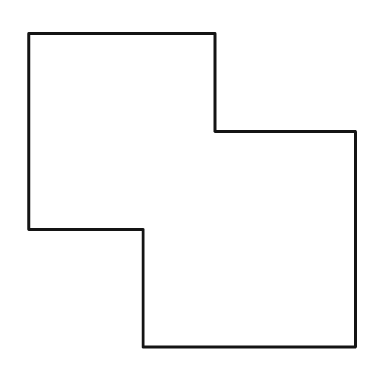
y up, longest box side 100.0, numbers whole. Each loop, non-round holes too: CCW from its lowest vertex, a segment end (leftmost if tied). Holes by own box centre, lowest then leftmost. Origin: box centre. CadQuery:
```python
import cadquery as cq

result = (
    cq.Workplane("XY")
    .moveTo(-15.0, -48.0)
    .lineTo(50.0, -48.0)
    .lineTo(50.0, 18.0)
    .lineTo(7.0, 18.0)
    .lineTo(7.0, 48.0)
    .lineTo(-50.0, 48.0)
    .lineTo(-50.0, -12.0)
    .lineTo(-15.0, -12.0)
    .close()
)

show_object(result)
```